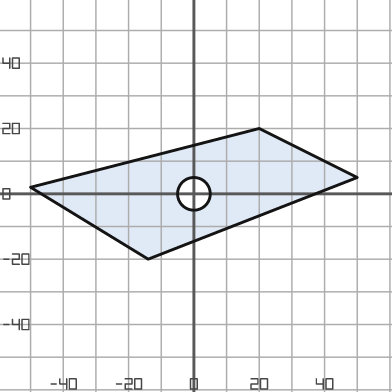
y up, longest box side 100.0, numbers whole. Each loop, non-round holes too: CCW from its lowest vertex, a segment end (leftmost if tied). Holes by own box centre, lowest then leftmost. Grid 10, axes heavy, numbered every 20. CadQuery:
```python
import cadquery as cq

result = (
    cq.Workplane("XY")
    .moveTo(-14.0, -20.0)
    .lineTo(50.0, 5.0)
    .lineTo(20.0, 20.0)
    .lineTo(-50.0, 2.0)
    .close()
    .moveTo(0.0, 0.0)
    .circle(5.0)
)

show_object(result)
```